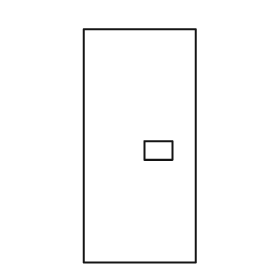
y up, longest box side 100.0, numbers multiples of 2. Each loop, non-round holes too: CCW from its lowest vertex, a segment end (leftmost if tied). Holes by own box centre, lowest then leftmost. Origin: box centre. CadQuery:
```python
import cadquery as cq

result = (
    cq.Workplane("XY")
    .moveTo(-24.0, -50.0)
    .lineTo(24.0, -50.0)
    .lineTo(24.0, 50.0)
    .lineTo(-24.0, 50.0)
    .close()
    .moveTo(2.0, -6.0)
    .lineTo(14.0, -6.0)
    .lineTo(14.0, 2.0)
    .lineTo(2.0, 2.0)
    .close()
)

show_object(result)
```